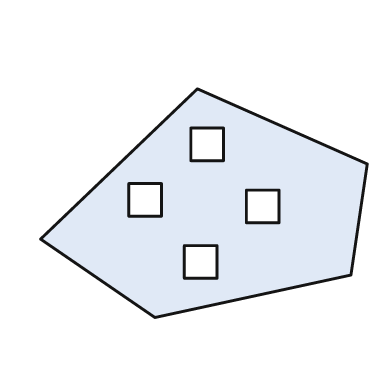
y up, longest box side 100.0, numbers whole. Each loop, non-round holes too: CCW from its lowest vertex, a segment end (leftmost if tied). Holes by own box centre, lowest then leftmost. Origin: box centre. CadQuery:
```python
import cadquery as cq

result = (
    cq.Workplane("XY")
    .moveTo(-15.0, -35.0)
    .lineTo(45.0, -22.0)
    .lineTo(50.0, 12.0)
    .lineTo(-2.0, 35.0)
    .lineTo(-50.0, -11.0)
    .close()
    .moveTo(-6.0, -23.0)
    .lineTo(4.0, -23.0)
    .lineTo(4.0, -13.0)
    .lineTo(-6.0, -13.0)
    .close()
    .moveTo(13.0, -6.0)
    .lineTo(23.0, -6.0)
    .lineTo(23.0, 4.0)
    .lineTo(13.0, 4.0)
    .close()
    .moveTo(-23.0, -4.0)
    .lineTo(-13.0, -4.0)
    .lineTo(-13.0, 6.0)
    .lineTo(-23.0, 6.0)
    .close()
    .moveTo(-4.0, 13.0)
    .lineTo(6.0, 13.0)
    .lineTo(6.0, 23.0)
    .lineTo(-4.0, 23.0)
    .close()
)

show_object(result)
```